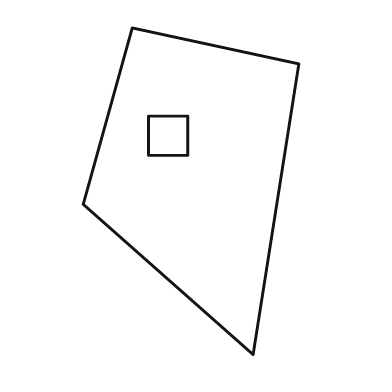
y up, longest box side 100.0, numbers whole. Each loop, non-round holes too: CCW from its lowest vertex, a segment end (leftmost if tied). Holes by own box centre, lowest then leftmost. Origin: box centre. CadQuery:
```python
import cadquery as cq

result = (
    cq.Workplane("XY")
    .moveTo(19.0, -50.0)
    .lineTo(33.0, 39.0)
    .lineTo(-18.0, 50.0)
    .lineTo(-33.0, -4.0)
    .close()
    .moveTo(-13.0, 11.0)
    .lineTo(-1.0, 11.0)
    .lineTo(-1.0, 23.0)
    .lineTo(-13.0, 23.0)
    .close()
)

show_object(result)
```